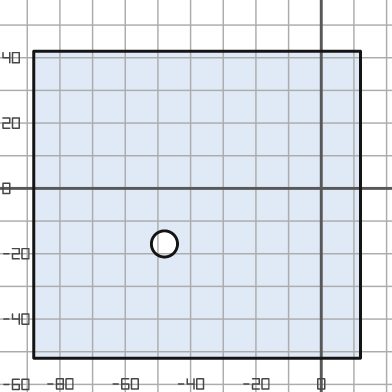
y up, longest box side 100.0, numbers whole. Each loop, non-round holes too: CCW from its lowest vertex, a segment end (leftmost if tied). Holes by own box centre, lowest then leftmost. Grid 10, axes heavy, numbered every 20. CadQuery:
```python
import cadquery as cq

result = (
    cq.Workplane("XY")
    .moveTo(-88.0, -52.0)
    .lineTo(12.0, -52.0)
    .lineTo(12.0, 42.0)
    .lineTo(-88.0, 42.0)
    .close()
    .moveTo(-48.0, -17.0)
    .circle(4.0)
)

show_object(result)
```